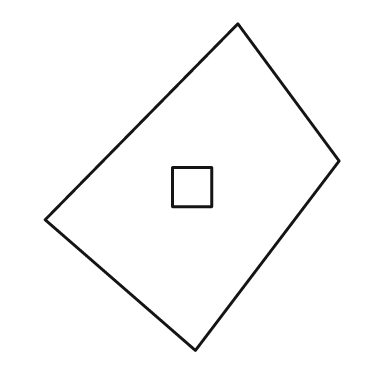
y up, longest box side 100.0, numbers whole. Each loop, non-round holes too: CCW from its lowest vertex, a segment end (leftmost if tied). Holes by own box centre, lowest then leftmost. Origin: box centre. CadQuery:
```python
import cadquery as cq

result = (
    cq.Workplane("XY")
    .moveTo(1.0, -50.0)
    .lineTo(45.0, 8.0)
    .lineTo(14.0, 50.0)
    .lineTo(-45.0, -10.0)
    .close()
    .moveTo(-6.0, -6.0)
    .lineTo(6.0, -6.0)
    .lineTo(6.0, 6.0)
    .lineTo(-6.0, 6.0)
    .close()
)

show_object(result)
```